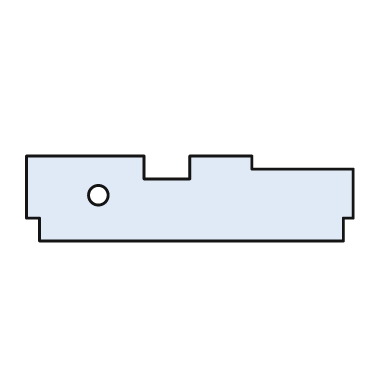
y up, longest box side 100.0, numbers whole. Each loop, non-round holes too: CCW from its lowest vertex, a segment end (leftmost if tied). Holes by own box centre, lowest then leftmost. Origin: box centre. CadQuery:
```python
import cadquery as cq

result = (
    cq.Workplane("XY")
    .moveTo(-46.0, -13.0)
    .lineTo(47.0, -13.0)
    .lineTo(47.0, -6.0)
    .lineTo(50.0, -6.0)
    .lineTo(50.0, 9.0)
    .lineTo(19.0, 9.0)
    .lineTo(19.0, 13.0)
    .lineTo(0.0, 13.0)
    .lineTo(0.0, 6.0)
    .lineTo(-14.0, 6.0)
    .lineTo(-14.0, 13.0)
    .lineTo(-50.0, 13.0)
    .lineTo(-50.0, -6.0)
    .lineTo(-46.0, -6.0)
    .close()
    .moveTo(-28.0, 1.0)
    .circle(3.0)
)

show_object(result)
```